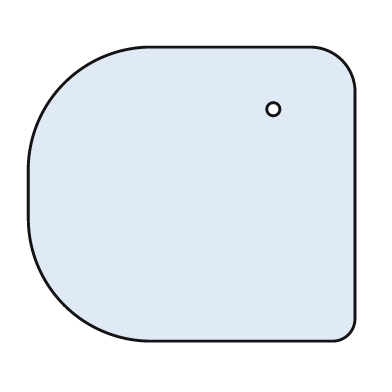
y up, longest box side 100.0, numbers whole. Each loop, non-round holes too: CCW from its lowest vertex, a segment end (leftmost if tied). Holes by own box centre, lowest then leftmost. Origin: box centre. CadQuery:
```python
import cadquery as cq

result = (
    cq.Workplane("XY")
    .moveTo(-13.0, -45.0)
    .lineTo(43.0, -45.0)
    .threePointArc((48.0, -43.0), (50.0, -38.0))
    .lineTo(50.0, 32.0)
    .threePointArc((46.0, 41.0), (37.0, 45.0))
    .lineTo(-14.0, 45.0)
    .threePointArc((-39.0, 34.0), (-50.0, 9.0))
    .lineTo(-50.0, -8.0)
    .threePointArc((-39.0, -34.0), (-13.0, -45.0))
    .close()
    .moveTo(25.0, 26.0)
    .circle(2.0)
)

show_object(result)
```